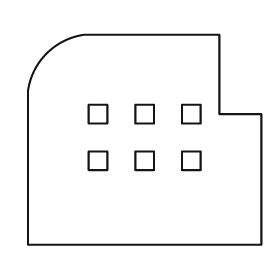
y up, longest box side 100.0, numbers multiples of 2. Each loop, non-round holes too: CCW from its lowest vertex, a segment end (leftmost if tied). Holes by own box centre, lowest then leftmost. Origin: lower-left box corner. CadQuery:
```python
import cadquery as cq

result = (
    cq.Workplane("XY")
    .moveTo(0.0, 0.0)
    .lineTo(100.0, 0.0)
    .lineTo(100.0, 56.0)
    .lineTo(82.0, 56.0)
    .lineTo(82.0, 90.0)
    .lineTo(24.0, 90.0)
    .threePointArc((8.0, 82.0), (0.0, 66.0))
    .close()
    .moveTo(26.0, 32.0)
    .lineTo(34.0, 32.0)
    .lineTo(34.0, 40.0)
    .lineTo(26.0, 40.0)
    .close()
    .moveTo(46.0, 32.0)
    .lineTo(54.0, 32.0)
    .lineTo(54.0, 40.0)
    .lineTo(46.0, 40.0)
    .close()
    .moveTo(66.0, 32.0)
    .lineTo(74.0, 32.0)
    .lineTo(74.0, 40.0)
    .lineTo(66.0, 40.0)
    .close()
    .moveTo(26.0, 52.0)
    .lineTo(34.0, 52.0)
    .lineTo(34.0, 60.0)
    .lineTo(26.0, 60.0)
    .close()
    .moveTo(46.0, 52.0)
    .lineTo(54.0, 52.0)
    .lineTo(54.0, 60.0)
    .lineTo(46.0, 60.0)
    .close()
    .moveTo(66.0, 52.0)
    .lineTo(74.0, 52.0)
    .lineTo(74.0, 60.0)
    .lineTo(66.0, 60.0)
    .close()
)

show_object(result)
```